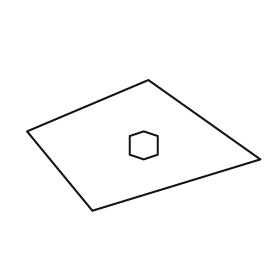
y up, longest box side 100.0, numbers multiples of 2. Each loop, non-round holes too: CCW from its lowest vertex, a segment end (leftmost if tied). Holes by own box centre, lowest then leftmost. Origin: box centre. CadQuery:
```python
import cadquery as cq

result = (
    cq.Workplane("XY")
    .moveTo(-22.0, -28.0)
    .lineTo(50.0, -6.0)
    .lineTo(2.0, 28.0)
    .lineTo(-50.0, 6.0)
    .close()
    .moveTo(0.0, -6.0)
    .lineTo(6.0, -4.0)
    .lineTo(6.0, 4.0)
    .lineTo(0.0, 6.0)
    .lineTo(-6.0, 4.0)
    .lineTo(-6.0, -4.0)
    .close()
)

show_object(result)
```